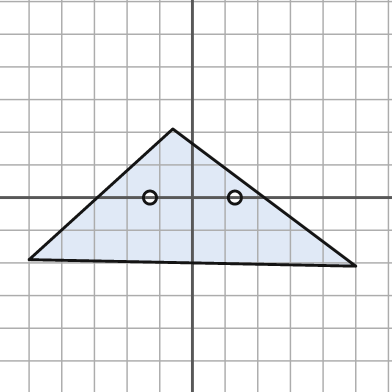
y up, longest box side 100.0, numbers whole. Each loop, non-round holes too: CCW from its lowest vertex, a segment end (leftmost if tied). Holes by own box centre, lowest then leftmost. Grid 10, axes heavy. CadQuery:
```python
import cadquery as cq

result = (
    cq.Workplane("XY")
    .moveTo(50.0, -21.0)
    .lineTo(-6.0, 21.0)
    .lineTo(-50.0, -19.0)
    .close()
    .moveTo(-13.0, 0.0)
    .circle(2.0)
    .moveTo(13.0, 0.0)
    .circle(2.0)
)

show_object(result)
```